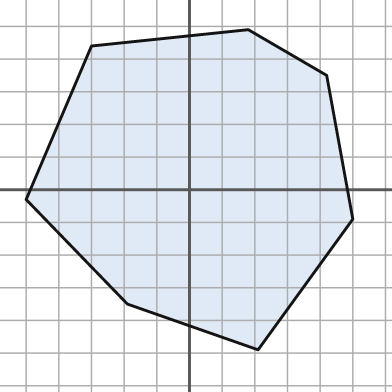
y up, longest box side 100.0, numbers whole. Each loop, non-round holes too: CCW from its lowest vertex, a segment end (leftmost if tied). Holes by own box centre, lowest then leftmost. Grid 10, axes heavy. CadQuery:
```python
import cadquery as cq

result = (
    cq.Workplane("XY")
    .moveTo(21.0, -49.0)
    .lineTo(50.0, -9.0)
    .lineTo(42.0, 35.0)
    .lineTo(18.0, 49.0)
    .lineTo(-30.0, 44.0)
    .lineTo(-50.0, -3.0)
    .lineTo(-19.0, -35.0)
    .close()
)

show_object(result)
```